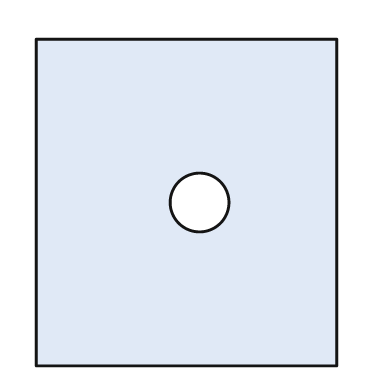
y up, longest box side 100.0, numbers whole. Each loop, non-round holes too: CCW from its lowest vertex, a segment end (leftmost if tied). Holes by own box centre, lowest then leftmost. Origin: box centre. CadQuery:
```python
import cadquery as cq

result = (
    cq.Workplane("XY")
    .moveTo(-46.0, -50.0)
    .lineTo(46.0, -50.0)
    .lineTo(46.0, 50.0)
    .lineTo(-46.0, 50.0)
    .close()
    .moveTo(4.0, 0.0)
    .circle(9.0)
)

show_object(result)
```